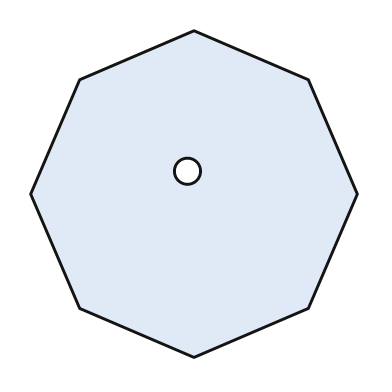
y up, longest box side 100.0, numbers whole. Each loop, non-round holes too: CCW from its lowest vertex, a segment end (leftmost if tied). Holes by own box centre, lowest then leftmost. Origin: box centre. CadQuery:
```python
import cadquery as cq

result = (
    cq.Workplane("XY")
    .moveTo(0.0, -50.0)
    .lineTo(35.0, -35.0)
    .lineTo(50.0, 0.0)
    .lineTo(35.0, 35.0)
    .lineTo(0.0, 50.0)
    .lineTo(-35.0, 35.0)
    .lineTo(-50.0, 0.0)
    .lineTo(-35.0, -35.0)
    .close()
    .moveTo(-2.0, 7.0)
    .circle(4.0)
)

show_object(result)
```